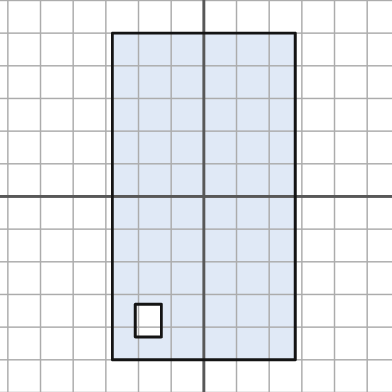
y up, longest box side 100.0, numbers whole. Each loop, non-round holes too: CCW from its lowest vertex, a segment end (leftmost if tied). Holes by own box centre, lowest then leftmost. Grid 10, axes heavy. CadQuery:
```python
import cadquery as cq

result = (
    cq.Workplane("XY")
    .moveTo(-28.0, -50.0)
    .lineTo(28.0, -50.0)
    .lineTo(28.0, 50.0)
    .lineTo(-28.0, 50.0)
    .close()
    .moveTo(-21.0, -43.0)
    .lineTo(-13.0, -43.0)
    .lineTo(-13.0, -33.0)
    .lineTo(-21.0, -33.0)
    .close()
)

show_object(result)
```